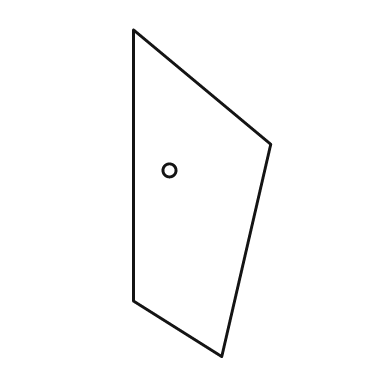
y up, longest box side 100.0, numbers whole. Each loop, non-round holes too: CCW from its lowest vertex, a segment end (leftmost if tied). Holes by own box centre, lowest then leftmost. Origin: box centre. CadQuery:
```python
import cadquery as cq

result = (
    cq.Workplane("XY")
    .moveTo(6.0, -50.0)
    .lineTo(21.0, 15.0)
    .lineTo(-21.0, 50.0)
    .lineTo(-21.0, -33.0)
    .close()
    .moveTo(-10.0, 7.0)
    .circle(2.0)
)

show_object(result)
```